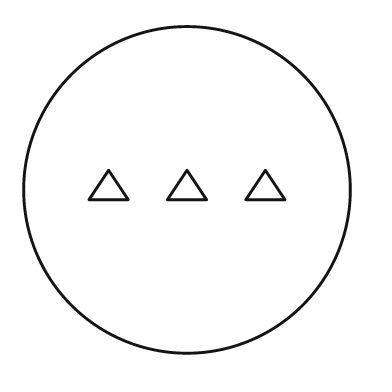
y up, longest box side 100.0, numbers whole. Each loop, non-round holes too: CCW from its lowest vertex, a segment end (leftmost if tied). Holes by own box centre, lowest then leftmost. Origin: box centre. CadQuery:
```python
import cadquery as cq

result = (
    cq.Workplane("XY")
    .moveTo(0.0, 0.0)
    .circle(50.0)
    .moveTo(-30.0, -3.0)
    .lineTo(-18.0, -3.0)
    .lineTo(-24.0, 6.0)
    .close()
    .moveTo(-6.0, -3.0)
    .lineTo(6.0, -3.0)
    .lineTo(0.0, 6.0)
    .close()
    .moveTo(18.0, -3.0)
    .lineTo(30.0, -3.0)
    .lineTo(24.0, 6.0)
    .close()
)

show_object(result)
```